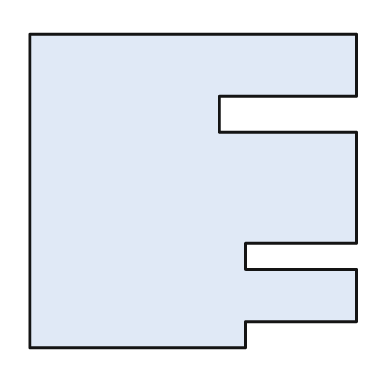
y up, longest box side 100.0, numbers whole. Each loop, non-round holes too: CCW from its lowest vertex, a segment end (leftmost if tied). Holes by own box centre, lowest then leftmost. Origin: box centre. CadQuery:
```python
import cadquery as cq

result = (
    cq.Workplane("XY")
    .moveTo(-50.0, -48.0)
    .lineTo(16.0, -48.0)
    .lineTo(16.0, -40.0)
    .lineTo(50.0, -40.0)
    .lineTo(50.0, -24.0)
    .lineTo(16.0, -24.0)
    .lineTo(16.0, -16.0)
    .lineTo(50.0, -16.0)
    .lineTo(50.0, 18.0)
    .lineTo(8.0, 18.0)
    .lineTo(8.0, 29.0)
    .lineTo(50.0, 29.0)
    .lineTo(50.0, 48.0)
    .lineTo(-50.0, 48.0)
    .close()
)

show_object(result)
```